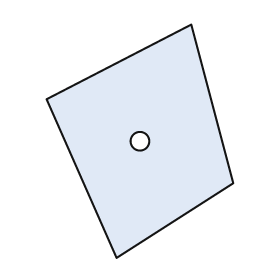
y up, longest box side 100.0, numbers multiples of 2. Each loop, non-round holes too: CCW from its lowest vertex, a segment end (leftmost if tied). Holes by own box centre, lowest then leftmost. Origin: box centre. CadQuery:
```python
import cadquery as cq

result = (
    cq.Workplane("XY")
    .moveTo(-10.0, -50.0)
    .lineTo(40.0, -18.0)
    .lineTo(22.0, 50.0)
    .lineTo(-40.0, 18.0)
    .close()
    .moveTo(0.0, 0.0)
    .circle(4.0)
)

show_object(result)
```